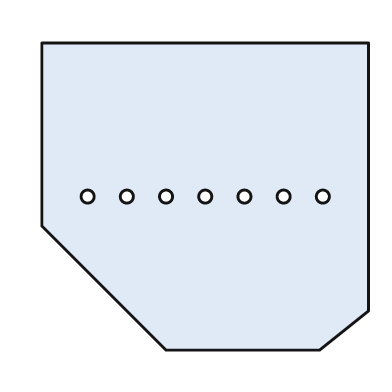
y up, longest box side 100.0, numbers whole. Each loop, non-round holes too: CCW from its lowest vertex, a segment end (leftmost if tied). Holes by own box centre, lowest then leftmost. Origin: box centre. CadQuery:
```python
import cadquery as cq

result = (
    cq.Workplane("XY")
    .moveTo(-12.0, -47.0)
    .lineTo(35.0, -47.0)
    .lineTo(50.0, -35.0)
    .lineTo(50.0, 47.0)
    .lineTo(-50.0, 47.0)
    .lineTo(-50.0, -9.0)
    .close()
    .moveTo(-36.0, 0.0)
    .circle(2.0)
    .moveTo(-24.0, 0.0)
    .circle(2.0)
    .moveTo(-12.0, 0.0)
    .circle(2.0)
    .moveTo(0.0, 0.0)
    .circle(2.0)
    .moveTo(12.0, 0.0)
    .circle(2.0)
    .moveTo(24.0, 0.0)
    .circle(2.0)
    .moveTo(36.0, 0.0)
    .circle(2.0)
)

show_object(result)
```